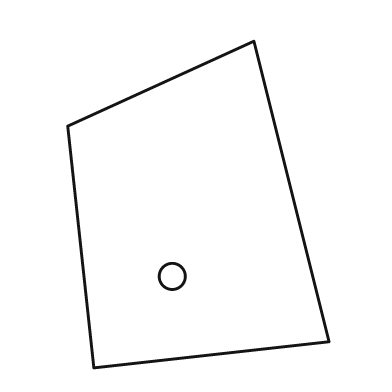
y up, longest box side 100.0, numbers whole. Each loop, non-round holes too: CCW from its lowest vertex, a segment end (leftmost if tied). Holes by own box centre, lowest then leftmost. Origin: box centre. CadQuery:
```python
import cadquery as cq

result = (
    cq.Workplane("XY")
    .moveTo(-32.0, -50.0)
    .lineTo(40.0, -42.0)
    .lineTo(17.0, 50.0)
    .lineTo(-40.0, 24.0)
    .close()
    .moveTo(-8.0, -22.0)
    .circle(4.0)
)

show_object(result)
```